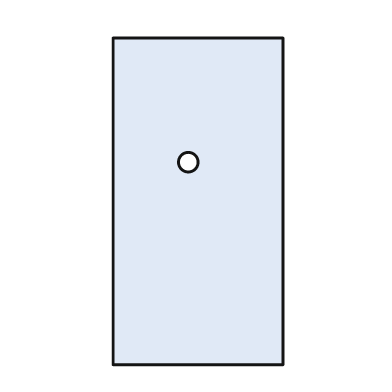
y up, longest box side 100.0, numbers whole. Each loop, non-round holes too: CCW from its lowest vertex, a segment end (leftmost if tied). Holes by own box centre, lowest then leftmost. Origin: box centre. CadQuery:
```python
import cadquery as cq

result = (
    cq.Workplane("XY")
    .moveTo(-26.0, -50.0)
    .lineTo(26.0, -50.0)
    .lineTo(26.0, 50.0)
    .lineTo(-26.0, 50.0)
    .close()
    .moveTo(-3.0, 12.0)
    .circle(3.0)
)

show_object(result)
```